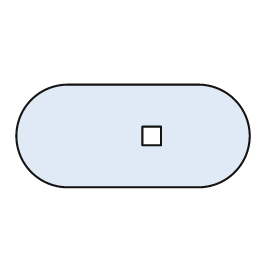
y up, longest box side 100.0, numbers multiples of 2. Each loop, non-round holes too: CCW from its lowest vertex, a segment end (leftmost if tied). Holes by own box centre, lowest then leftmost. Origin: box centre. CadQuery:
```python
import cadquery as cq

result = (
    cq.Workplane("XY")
    .moveTo(-28.0, -22.0)
    .lineTo(28.0, -22.0)
    .threePointArc((50.0, 0.0), (28.0, 22.0))
    .lineTo(-28.0, 22.0)
    .threePointArc((-50.0, 0.0), (-28.0, -22.0))
    .close()
    .moveTo(4.0, -4.0)
    .lineTo(12.0, -4.0)
    .lineTo(12.0, 4.0)
    .lineTo(4.0, 4.0)
    .close()
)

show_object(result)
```